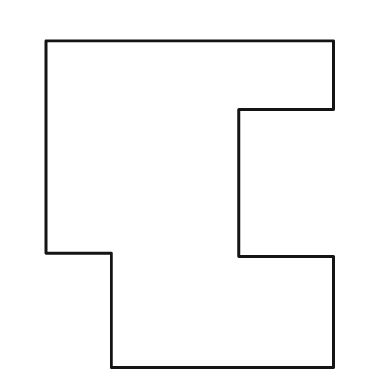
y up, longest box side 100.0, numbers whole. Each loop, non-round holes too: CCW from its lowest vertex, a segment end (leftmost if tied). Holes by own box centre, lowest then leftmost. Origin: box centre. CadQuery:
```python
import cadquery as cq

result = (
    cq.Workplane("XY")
    .moveTo(-24.0, -50.0)
    .lineTo(44.0, -50.0)
    .lineTo(44.0, -16.0)
    .lineTo(15.0, -16.0)
    .lineTo(15.0, 29.0)
    .lineTo(44.0, 29.0)
    .lineTo(44.0, 50.0)
    .lineTo(-44.0, 50.0)
    .lineTo(-44.0, -15.0)
    .lineTo(-24.0, -15.0)
    .close()
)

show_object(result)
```